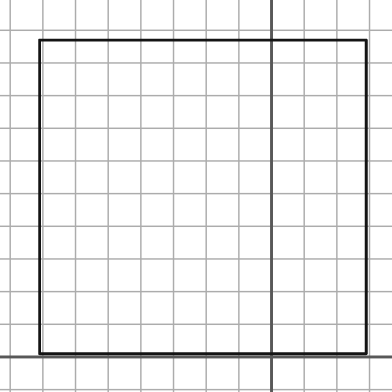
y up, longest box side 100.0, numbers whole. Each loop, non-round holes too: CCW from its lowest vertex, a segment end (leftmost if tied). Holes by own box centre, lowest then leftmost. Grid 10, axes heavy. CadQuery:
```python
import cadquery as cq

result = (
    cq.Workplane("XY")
    .moveTo(-71.0, 1.0)
    .lineTo(29.0, 1.0)
    .lineTo(29.0, 97.0)
    .lineTo(-71.0, 97.0)
    .close()
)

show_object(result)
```